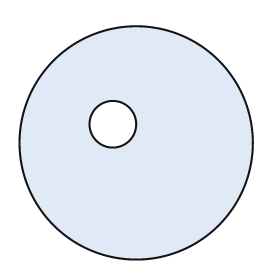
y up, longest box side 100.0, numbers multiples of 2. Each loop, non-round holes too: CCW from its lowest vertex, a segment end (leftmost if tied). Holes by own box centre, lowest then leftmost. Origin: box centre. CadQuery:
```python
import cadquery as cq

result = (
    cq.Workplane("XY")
    .moveTo(0.0, 0.0)
    .circle(50.0)
    .moveTo(-10.0, 8.0)
    .circle(10.0)
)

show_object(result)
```